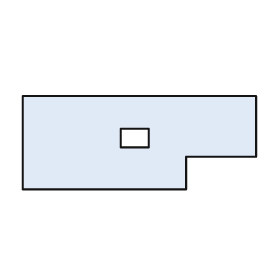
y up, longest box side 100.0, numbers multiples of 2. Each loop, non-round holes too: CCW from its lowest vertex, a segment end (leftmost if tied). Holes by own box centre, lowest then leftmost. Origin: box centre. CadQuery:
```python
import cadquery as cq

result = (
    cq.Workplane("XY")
    .moveTo(-50.0, -20.0)
    .lineTo(20.0, -20.0)
    .lineTo(20.0, -6.0)
    .lineTo(50.0, -6.0)
    .lineTo(50.0, 20.0)
    .lineTo(-50.0, 20.0)
    .close()
    .moveTo(-8.0, -2.0)
    .lineTo(4.0, -2.0)
    .lineTo(4.0, 6.0)
    .lineTo(-8.0, 6.0)
    .close()
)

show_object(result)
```